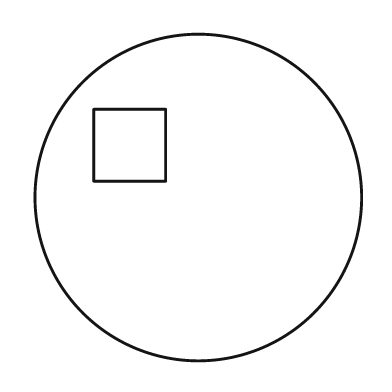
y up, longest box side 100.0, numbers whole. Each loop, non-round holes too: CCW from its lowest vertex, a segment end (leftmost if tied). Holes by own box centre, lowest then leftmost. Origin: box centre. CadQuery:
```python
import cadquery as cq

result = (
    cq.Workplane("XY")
    .moveTo(0.0, 0.0)
    .circle(50.0)
    .moveTo(-32.0, 5.0)
    .lineTo(-10.0, 5.0)
    .lineTo(-10.0, 27.0)
    .lineTo(-32.0, 27.0)
    .close()
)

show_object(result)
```